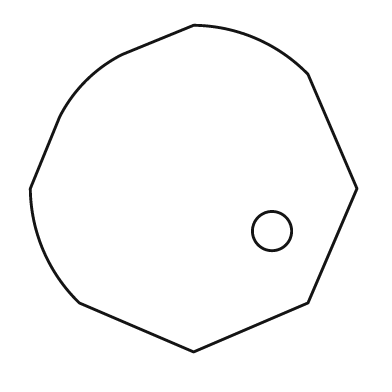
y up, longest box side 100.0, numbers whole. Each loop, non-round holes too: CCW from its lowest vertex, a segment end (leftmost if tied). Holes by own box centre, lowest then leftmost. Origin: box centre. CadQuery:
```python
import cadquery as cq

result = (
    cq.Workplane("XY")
    .moveTo(0.0, -50.0)
    .lineTo(35.0, -35.0)
    .lineTo(50.0, 0.0)
    .lineTo(35.0, 35.0)
    .threePointArc((19.0, 46.0), (0.0, 50.0))
    .lineTo(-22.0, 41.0)
    .threePointArc((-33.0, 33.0), (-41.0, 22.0))
    .lineTo(-50.0, 0.0)
    .threePointArc((-46.0, -19.0), (-35.0, -35.0))
    .close()
    .moveTo(24.0, -13.0)
    .circle(6.0)
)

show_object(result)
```